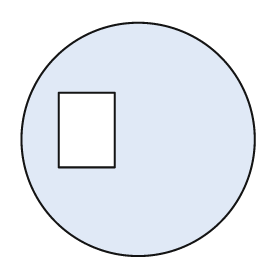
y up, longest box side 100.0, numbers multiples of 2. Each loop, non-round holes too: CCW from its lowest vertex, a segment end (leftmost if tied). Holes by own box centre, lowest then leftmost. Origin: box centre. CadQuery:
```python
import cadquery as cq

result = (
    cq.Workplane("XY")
    .moveTo(0.0, 0.0)
    .circle(50.0)
    .moveTo(-34.0, -12.0)
    .lineTo(-10.0, -12.0)
    .lineTo(-10.0, 20.0)
    .lineTo(-34.0, 20.0)
    .close()
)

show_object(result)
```